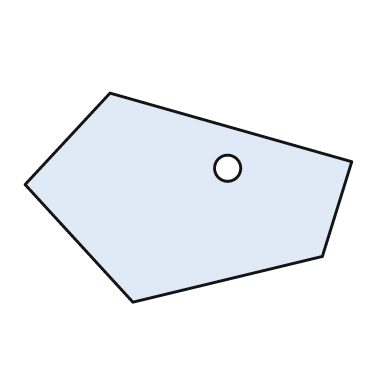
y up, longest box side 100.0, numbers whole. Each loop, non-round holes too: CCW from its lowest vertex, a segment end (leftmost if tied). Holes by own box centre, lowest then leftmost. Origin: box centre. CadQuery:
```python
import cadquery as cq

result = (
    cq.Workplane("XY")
    .moveTo(-17.0, -32.0)
    .lineTo(41.0, -18.0)
    .lineTo(50.0, 11.0)
    .lineTo(-24.0, 32.0)
    .lineTo(-50.0, 4.0)
    .close()
    .moveTo(12.0, 9.0)
    .circle(4.0)
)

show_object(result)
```